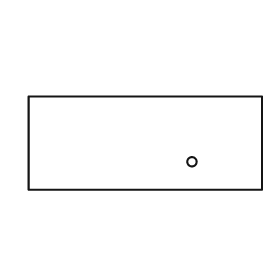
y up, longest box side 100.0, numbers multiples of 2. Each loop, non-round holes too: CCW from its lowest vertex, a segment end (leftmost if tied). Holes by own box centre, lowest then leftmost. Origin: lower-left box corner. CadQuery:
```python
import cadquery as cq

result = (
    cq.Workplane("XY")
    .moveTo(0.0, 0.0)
    .lineTo(100.0, 0.0)
    .lineTo(100.0, 40.0)
    .lineTo(0.0, 40.0)
    .close()
    .moveTo(70.0, 12.0)
    .circle(2.0)
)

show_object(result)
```